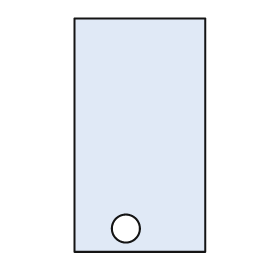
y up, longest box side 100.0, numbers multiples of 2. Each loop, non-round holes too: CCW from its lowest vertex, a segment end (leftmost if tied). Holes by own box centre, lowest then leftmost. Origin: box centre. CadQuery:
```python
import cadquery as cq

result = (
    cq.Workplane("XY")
    .moveTo(-28.0, -50.0)
    .lineTo(28.0, -50.0)
    .lineTo(28.0, 50.0)
    .lineTo(-28.0, 50.0)
    .close()
    .moveTo(-6.0, -40.0)
    .circle(6.0)
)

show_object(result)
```